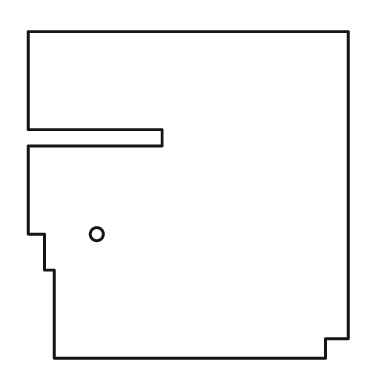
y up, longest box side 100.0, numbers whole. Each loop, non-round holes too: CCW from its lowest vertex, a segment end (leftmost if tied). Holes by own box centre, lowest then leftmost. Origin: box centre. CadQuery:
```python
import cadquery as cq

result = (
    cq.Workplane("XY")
    .moveTo(-41.0, -50.0)
    .lineTo(42.0, -50.0)
    .lineTo(42.0, -44.0)
    .lineTo(49.0, -44.0)
    .lineTo(49.0, 50.0)
    .lineTo(-49.0, 50.0)
    .lineTo(-49.0, 20.0)
    .lineTo(-8.0, 20.0)
    .lineTo(-8.0, 15.0)
    .lineTo(-49.0, 15.0)
    .lineTo(-49.0, -12.0)
    .lineTo(-44.0, -12.0)
    .lineTo(-44.0, -23.0)
    .lineTo(-41.0, -23.0)
    .close()
    .moveTo(-28.0, -12.0)
    .circle(2.0)
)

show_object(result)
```